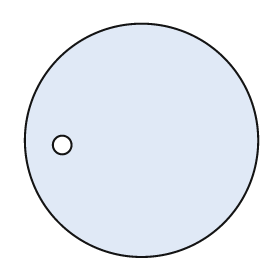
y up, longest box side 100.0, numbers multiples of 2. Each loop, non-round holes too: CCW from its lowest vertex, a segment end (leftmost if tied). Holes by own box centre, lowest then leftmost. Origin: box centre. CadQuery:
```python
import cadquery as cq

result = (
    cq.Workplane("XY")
    .moveTo(0.0, 0.0)
    .circle(50.0)
    .moveTo(-34.0, -2.0)
    .circle(4.0)
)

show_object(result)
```